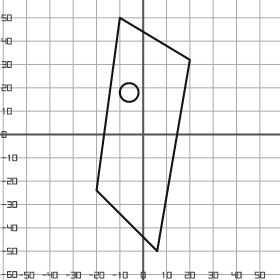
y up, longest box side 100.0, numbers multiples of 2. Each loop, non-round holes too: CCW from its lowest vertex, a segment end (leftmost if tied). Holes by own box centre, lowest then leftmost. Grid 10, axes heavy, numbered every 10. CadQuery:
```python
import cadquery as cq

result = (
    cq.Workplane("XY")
    .moveTo(6.0, -50.0)
    .lineTo(20.0, 32.0)
    .lineTo(-10.0, 50.0)
    .lineTo(-20.0, -24.0)
    .close()
    .moveTo(-6.0, 18.0)
    .circle(4.0)
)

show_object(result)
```